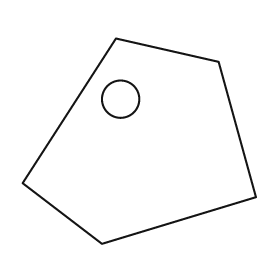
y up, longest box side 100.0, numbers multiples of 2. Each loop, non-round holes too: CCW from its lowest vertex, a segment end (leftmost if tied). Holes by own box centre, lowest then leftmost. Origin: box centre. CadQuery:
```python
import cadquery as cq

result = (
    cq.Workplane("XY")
    .moveTo(-16.0, -44.0)
    .lineTo(50.0, -24.0)
    .lineTo(34.0, 34.0)
    .lineTo(-10.0, 44.0)
    .lineTo(-50.0, -18.0)
    .close()
    .moveTo(-8.0, 18.0)
    .circle(8.0)
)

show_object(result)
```